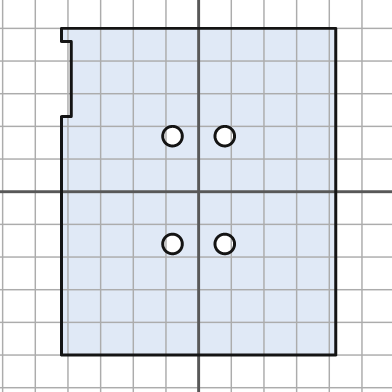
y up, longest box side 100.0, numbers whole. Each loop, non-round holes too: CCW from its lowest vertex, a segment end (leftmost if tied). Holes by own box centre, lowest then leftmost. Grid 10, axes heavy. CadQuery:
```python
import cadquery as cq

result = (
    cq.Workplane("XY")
    .moveTo(-42.0, -50.0)
    .lineTo(42.0, -50.0)
    .lineTo(42.0, 50.0)
    .lineTo(-42.0, 50.0)
    .lineTo(-42.0, 46.0)
    .lineTo(-39.0, 46.0)
    .lineTo(-39.0, 23.0)
    .lineTo(-42.0, 23.0)
    .close()
    .moveTo(-8.0, -16.0)
    .circle(3.0)
    .moveTo(8.0, -16.0)
    .circle(3.0)
    .moveTo(-8.0, 17.0)
    .circle(3.0)
    .moveTo(8.0, 17.0)
    .circle(3.0)
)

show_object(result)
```